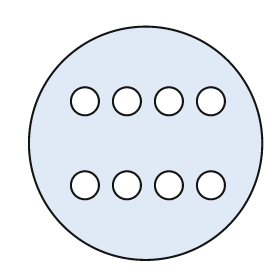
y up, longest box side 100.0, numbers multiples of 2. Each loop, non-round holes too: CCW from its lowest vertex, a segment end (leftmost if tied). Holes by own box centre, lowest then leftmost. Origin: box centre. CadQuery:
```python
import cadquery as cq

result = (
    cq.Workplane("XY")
    .moveTo(0.0, 0.0)
    .circle(50.0)
    .moveTo(-26.0, -18.0)
    .circle(6.0)
    .moveTo(-8.0, -18.0)
    .circle(6.0)
    .moveTo(10.0, -18.0)
    .circle(6.0)
    .moveTo(28.0, -18.0)
    .circle(6.0)
    .moveTo(-26.0, 18.0)
    .circle(6.0)
    .moveTo(-8.0, 18.0)
    .circle(6.0)
    .moveTo(10.0, 18.0)
    .circle(6.0)
    .moveTo(28.0, 18.0)
    .circle(6.0)
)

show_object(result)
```